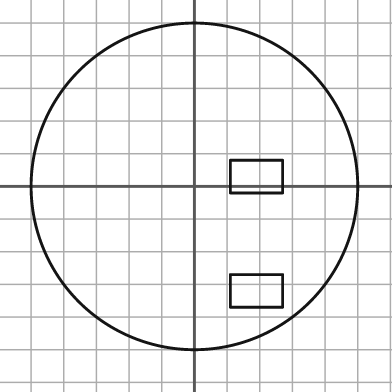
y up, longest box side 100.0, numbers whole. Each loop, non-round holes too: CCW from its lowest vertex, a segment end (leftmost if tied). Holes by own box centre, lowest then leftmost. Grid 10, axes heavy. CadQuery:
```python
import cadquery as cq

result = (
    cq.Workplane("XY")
    .moveTo(0.0, 0.0)
    .circle(50.0)
    .moveTo(11.0, -37.0)
    .lineTo(27.0, -37.0)
    .lineTo(27.0, -27.0)
    .lineTo(11.0, -27.0)
    .close()
    .moveTo(11.0, -2.0)
    .lineTo(27.0, -2.0)
    .lineTo(27.0, 8.0)
    .lineTo(11.0, 8.0)
    .close()
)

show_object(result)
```